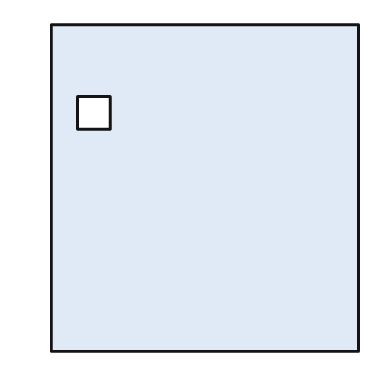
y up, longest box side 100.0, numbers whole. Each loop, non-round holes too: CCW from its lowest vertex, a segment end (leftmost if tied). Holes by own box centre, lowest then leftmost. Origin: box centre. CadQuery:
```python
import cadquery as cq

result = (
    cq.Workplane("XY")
    .moveTo(-47.0, -50.0)
    .lineTo(47.0, -50.0)
    .lineTo(47.0, 50.0)
    .lineTo(-47.0, 50.0)
    .close()
    .moveTo(-39.0, 18.0)
    .lineTo(-29.0, 18.0)
    .lineTo(-29.0, 28.0)
    .lineTo(-39.0, 28.0)
    .close()
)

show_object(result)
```